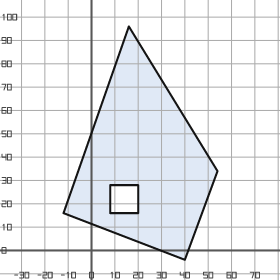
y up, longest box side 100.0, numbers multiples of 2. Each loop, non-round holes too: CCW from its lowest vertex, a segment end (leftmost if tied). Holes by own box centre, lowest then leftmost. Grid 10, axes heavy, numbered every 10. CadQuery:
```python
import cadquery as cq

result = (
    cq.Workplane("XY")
    .moveTo(40.0, -4.0)
    .lineTo(54.0, 34.0)
    .lineTo(16.0, 96.0)
    .lineTo(-12.0, 16.0)
    .close()
    .moveTo(8.0, 16.0)
    .lineTo(20.0, 16.0)
    .lineTo(20.0, 28.0)
    .lineTo(8.0, 28.0)
    .close()
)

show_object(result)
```